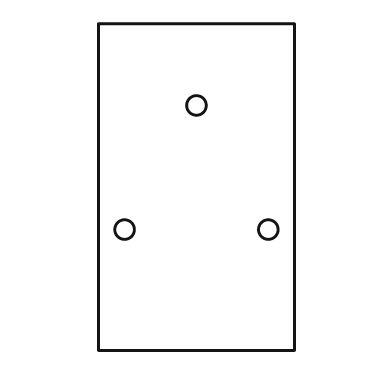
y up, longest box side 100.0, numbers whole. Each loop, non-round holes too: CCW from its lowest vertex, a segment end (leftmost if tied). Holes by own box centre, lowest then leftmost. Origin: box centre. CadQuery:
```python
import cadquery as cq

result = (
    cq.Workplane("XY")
    .moveTo(-30.0, -50.0)
    .lineTo(30.0, -50.0)
    .lineTo(30.0, 50.0)
    .lineTo(-30.0, 50.0)
    .close()
    .moveTo(-22.0, -13.0)
    .circle(3.0)
    .moveTo(22.0, -13.0)
    .circle(3.0)
    .moveTo(0.0, 25.0)
    .circle(3.0)
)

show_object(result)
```